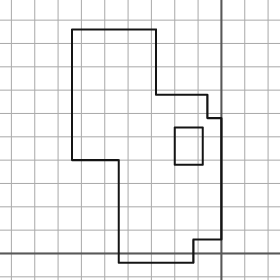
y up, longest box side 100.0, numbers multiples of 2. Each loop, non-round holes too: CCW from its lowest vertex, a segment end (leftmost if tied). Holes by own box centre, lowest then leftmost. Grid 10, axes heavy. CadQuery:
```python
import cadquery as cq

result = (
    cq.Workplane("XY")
    .moveTo(-44.0, -4.0)
    .lineTo(-12.0, -4.0)
    .lineTo(-12.0, 6.0)
    .lineTo(0.0, 6.0)
    .lineTo(0.0, 58.0)
    .lineTo(-6.0, 58.0)
    .lineTo(-6.0, 68.0)
    .lineTo(-28.0, 68.0)
    .lineTo(-28.0, 96.0)
    .lineTo(-64.0, 96.0)
    .lineTo(-64.0, 40.0)
    .lineTo(-44.0, 40.0)
    .close()
    .moveTo(-20.0, 38.0)
    .lineTo(-8.0, 38.0)
    .lineTo(-8.0, 54.0)
    .lineTo(-20.0, 54.0)
    .close()
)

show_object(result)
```